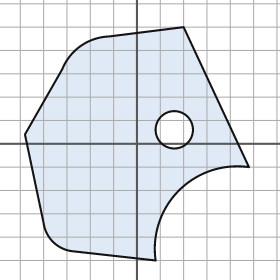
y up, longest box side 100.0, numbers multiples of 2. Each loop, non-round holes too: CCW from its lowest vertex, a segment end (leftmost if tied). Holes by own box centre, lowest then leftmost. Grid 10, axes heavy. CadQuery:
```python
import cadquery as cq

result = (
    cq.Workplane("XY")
    .moveTo(8.0, -50.0)
    .threePointArc((18.0, -20.0), (48.0, -10.0))
    .lineTo(20.0, 50.0)
    .lineTo(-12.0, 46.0)
    .threePointArc((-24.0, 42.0), (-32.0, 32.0))
    .lineTo(-48.0, 4.0)
    .lineTo(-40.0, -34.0)
    .threePointArc((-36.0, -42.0), (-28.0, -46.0))
    .close()
    .moveTo(16.0, 6.0)
    .circle(8.0)
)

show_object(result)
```